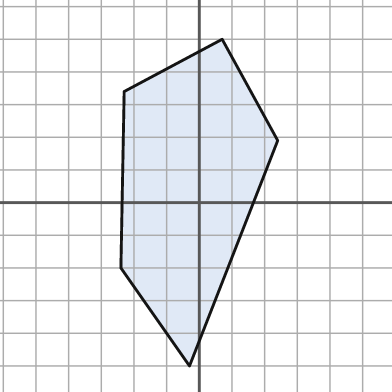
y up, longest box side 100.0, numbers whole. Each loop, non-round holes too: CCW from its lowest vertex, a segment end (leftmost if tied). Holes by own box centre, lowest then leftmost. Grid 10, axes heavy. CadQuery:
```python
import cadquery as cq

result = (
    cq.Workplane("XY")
    .moveTo(-3.0, -50.0)
    .lineTo(24.0, 19.0)
    .lineTo(7.0, 50.0)
    .lineTo(-23.0, 34.0)
    .lineTo(-24.0, -20.0)
    .close()
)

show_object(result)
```